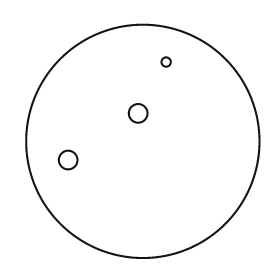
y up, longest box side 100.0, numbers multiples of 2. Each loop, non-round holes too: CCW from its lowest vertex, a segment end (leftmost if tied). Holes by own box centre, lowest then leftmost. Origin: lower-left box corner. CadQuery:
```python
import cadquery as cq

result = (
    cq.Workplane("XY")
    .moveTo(50.0, 50.0)
    .circle(50.0)
    .moveTo(18.0, 42.0)
    .circle(4.0)
    .moveTo(48.0, 62.0)
    .circle(4.0)
    .moveTo(60.0, 84.0)
    .circle(2.0)
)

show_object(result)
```